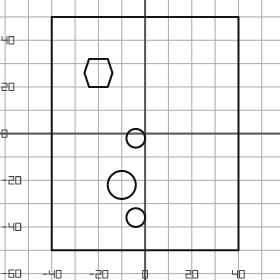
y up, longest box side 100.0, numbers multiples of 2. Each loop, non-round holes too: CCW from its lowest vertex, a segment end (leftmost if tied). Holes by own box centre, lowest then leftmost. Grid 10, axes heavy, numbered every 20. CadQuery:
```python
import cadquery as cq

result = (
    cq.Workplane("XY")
    .moveTo(-40.0, -50.0)
    .lineTo(40.0, -50.0)
    .lineTo(40.0, 50.0)
    .lineTo(-40.0, 50.0)
    .close()
    .moveTo(-4.0, -36.0)
    .circle(4.0)
    .moveTo(-10.0, -22.0)
    .circle(6.0)
    .moveTo(-4.0, -2.0)
    .circle(4.0)
    .moveTo(-24.0, 20.0)
    .lineTo(-16.0, 20.0)
    .lineTo(-14.0, 26.0)
    .lineTo(-16.0, 32.0)
    .lineTo(-24.0, 32.0)
    .lineTo(-26.0, 26.0)
    .close()
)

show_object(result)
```